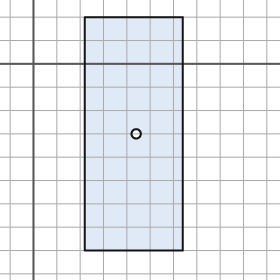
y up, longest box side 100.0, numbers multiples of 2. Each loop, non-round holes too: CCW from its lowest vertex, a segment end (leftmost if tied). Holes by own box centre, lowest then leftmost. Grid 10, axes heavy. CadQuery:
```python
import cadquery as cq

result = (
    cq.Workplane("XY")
    .moveTo(22.0, -80.0)
    .lineTo(64.0, -80.0)
    .lineTo(64.0, 20.0)
    .lineTo(22.0, 20.0)
    .close()
    .moveTo(44.0, -30.0)
    .circle(2.0)
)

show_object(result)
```